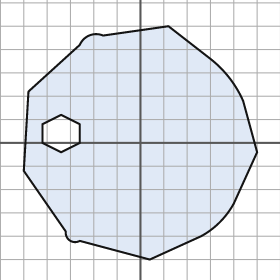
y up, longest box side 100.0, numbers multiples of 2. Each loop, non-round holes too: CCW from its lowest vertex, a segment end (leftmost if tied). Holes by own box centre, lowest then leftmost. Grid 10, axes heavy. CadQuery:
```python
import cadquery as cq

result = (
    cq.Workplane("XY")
    .moveTo(4.0, -50.0)
    .lineTo(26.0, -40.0)
    .threePointArc((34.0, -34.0), (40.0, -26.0))
    .lineTo(50.0, -4.0)
    .lineTo(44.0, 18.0)
    .threePointArc((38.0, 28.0), (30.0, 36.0))
    .lineTo(12.0, 50.0)
    .lineTo(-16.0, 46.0)
    .threePointArc((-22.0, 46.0), (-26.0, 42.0))
    .lineTo(-48.0, 22.0)
    .lineTo(-50.0, -12.0)
    .lineTo(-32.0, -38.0)
    .threePointArc((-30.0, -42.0), (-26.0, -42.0))
    .close()
    .moveTo(-34.0, -4.0)
    .lineTo(-26.0, 0.0)
    .lineTo(-26.0, 8.0)
    .lineTo(-34.0, 12.0)
    .lineTo(-42.0, 8.0)
    .lineTo(-42.0, 0.0)
    .close()
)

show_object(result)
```